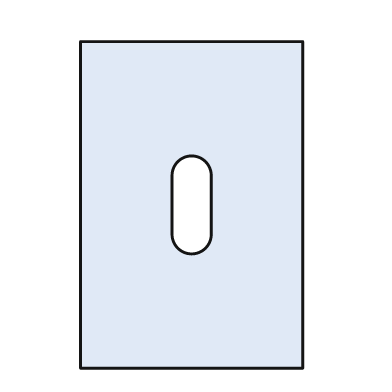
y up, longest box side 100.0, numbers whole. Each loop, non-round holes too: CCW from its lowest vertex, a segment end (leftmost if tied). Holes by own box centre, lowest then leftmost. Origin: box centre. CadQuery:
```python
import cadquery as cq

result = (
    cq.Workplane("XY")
    .moveTo(-34.0, -50.0)
    .lineTo(34.0, -50.0)
    .lineTo(34.0, 50.0)
    .lineTo(-34.0, 50.0)
    .close()
    .moveTo(-6.0, -9.0)
    .threePointArc((0.0, -15.0), (6.0, -9.0))
    .lineTo(6.0, 9.0)
    .threePointArc((0.0, 15.0), (-6.0, 9.0))
    .close()
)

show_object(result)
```